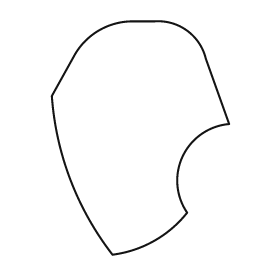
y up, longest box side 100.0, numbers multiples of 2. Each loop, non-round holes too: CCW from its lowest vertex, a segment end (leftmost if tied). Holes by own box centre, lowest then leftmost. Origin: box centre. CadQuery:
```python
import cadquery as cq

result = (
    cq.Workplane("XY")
    .moveTo(-12.0, -50.0)
    .threePointArc((6.0, -44.0), (20.0, -32.0))
    .threePointArc((18.0, -8.0), (38.0, 6.0))
    .lineTo(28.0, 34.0)
    .threePointArc((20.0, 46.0), (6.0, 50.0))
    .lineTo(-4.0, 50.0)
    .threePointArc((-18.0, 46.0), (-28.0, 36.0))
    .lineTo(-38.0, 18.0)
    .threePointArc((-30.0, -18.0), (-12.0, -50.0))
    .close()
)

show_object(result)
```